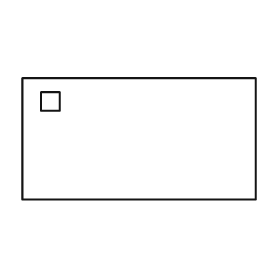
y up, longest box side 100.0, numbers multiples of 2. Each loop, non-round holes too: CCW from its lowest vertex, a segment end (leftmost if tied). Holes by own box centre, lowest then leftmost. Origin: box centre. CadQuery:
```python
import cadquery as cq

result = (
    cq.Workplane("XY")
    .moveTo(-50.0, -26.0)
    .lineTo(50.0, -26.0)
    .lineTo(50.0, 26.0)
    .lineTo(-50.0, 26.0)
    .close()
    .moveTo(-42.0, 12.0)
    .lineTo(-34.0, 12.0)
    .lineTo(-34.0, 20.0)
    .lineTo(-42.0, 20.0)
    .close()
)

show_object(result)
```